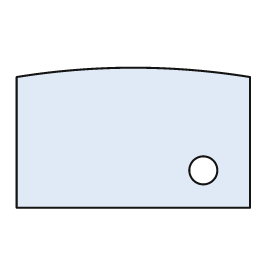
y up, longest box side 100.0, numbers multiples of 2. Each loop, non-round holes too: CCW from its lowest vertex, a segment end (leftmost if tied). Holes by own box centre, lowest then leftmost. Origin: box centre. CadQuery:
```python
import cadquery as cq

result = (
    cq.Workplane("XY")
    .moveTo(-50.0, -30.0)
    .lineTo(50.0, -30.0)
    .lineTo(50.0, 26.0)
    .threePointArc((0.0, 30.0), (-50.0, 26.0))
    .close()
    .moveTo(30.0, -14.0)
    .circle(6.0)
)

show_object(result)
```